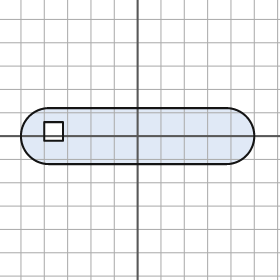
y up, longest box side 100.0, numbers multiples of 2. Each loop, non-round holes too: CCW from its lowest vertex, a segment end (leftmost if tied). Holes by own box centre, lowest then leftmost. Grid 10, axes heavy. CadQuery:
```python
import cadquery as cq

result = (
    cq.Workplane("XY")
    .moveTo(-38.0, -12.0)
    .lineTo(38.0, -12.0)
    .threePointArc((50.0, 0.0), (38.0, 12.0))
    .lineTo(-38.0, 12.0)
    .threePointArc((-50.0, 0.0), (-38.0, -12.0))
    .close()
    .moveTo(-40.0, -2.0)
    .lineTo(-32.0, -2.0)
    .lineTo(-32.0, 6.0)
    .lineTo(-40.0, 6.0)
    .close()
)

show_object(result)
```